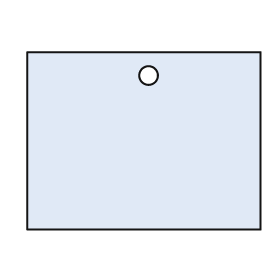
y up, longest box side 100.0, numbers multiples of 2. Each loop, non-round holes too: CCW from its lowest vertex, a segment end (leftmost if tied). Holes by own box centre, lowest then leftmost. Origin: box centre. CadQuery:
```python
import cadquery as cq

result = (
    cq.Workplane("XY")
    .moveTo(-50.0, -38.0)
    .lineTo(50.0, -38.0)
    .lineTo(50.0, 38.0)
    .lineTo(-50.0, 38.0)
    .close()
    .moveTo(2.0, 28.0)
    .circle(4.0)
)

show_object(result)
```